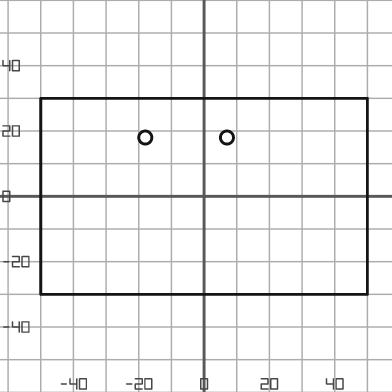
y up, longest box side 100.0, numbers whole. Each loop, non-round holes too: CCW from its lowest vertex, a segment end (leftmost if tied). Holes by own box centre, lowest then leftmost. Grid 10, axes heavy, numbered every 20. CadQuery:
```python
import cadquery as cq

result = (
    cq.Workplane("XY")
    .moveTo(-50.0, -30.0)
    .lineTo(50.0, -30.0)
    .lineTo(50.0, 30.0)
    .lineTo(-50.0, 30.0)
    .close()
    .moveTo(-18.0, 18.0)
    .circle(2.0)
    .moveTo(7.0, 18.0)
    .circle(2.0)
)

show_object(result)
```